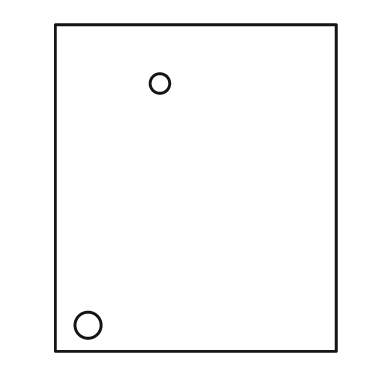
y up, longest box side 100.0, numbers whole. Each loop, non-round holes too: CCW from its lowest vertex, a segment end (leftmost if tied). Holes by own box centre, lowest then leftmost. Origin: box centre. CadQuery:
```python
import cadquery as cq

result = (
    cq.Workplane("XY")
    .moveTo(-43.0, -50.0)
    .lineTo(43.0, -50.0)
    .lineTo(43.0, 50.0)
    .lineTo(-43.0, 50.0)
    .close()
    .moveTo(-33.0, -42.0)
    .circle(4.0)
    .moveTo(-11.0, 32.0)
    .circle(3.0)
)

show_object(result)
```